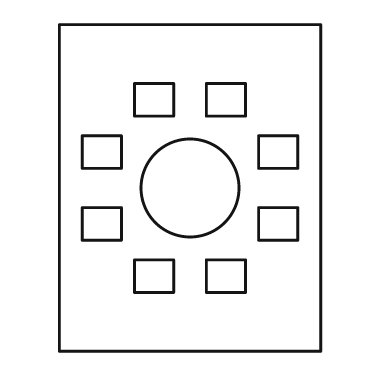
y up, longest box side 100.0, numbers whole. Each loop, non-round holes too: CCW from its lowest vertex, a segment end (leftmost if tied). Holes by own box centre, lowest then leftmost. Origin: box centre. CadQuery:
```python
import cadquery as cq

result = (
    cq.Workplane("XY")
    .moveTo(-40.0, -50.0)
    .lineTo(40.0, -50.0)
    .lineTo(40.0, 50.0)
    .lineTo(-40.0, 50.0)
    .close()
    .moveTo(-17.0, -32.0)
    .lineTo(-5.0, -32.0)
    .lineTo(-5.0, -22.0)
    .lineTo(-17.0, -22.0)
    .close()
    .moveTo(5.0, -32.0)
    .lineTo(17.0, -32.0)
    .lineTo(17.0, -22.0)
    .lineTo(5.0, -22.0)
    .close()
    .moveTo(-33.0, -16.0)
    .lineTo(-21.0, -16.0)
    .lineTo(-21.0, -6.0)
    .lineTo(-33.0, -6.0)
    .close()
    .moveTo(21.0, -16.0)
    .lineTo(33.0, -16.0)
    .lineTo(33.0, -6.0)
    .lineTo(21.0, -6.0)
    .close()
    .moveTo(0.0, 0.0)
    .circle(15.0)
    .moveTo(-33.0, 6.0)
    .lineTo(-21.0, 6.0)
    .lineTo(-21.0, 16.0)
    .lineTo(-33.0, 16.0)
    .close()
    .moveTo(21.0, 6.0)
    .lineTo(33.0, 6.0)
    .lineTo(33.0, 16.0)
    .lineTo(21.0, 16.0)
    .close()
    .moveTo(-17.0, 22.0)
    .lineTo(-5.0, 22.0)
    .lineTo(-5.0, 32.0)
    .lineTo(-17.0, 32.0)
    .close()
    .moveTo(5.0, 22.0)
    .lineTo(17.0, 22.0)
    .lineTo(17.0, 32.0)
    .lineTo(5.0, 32.0)
    .close()
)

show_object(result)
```